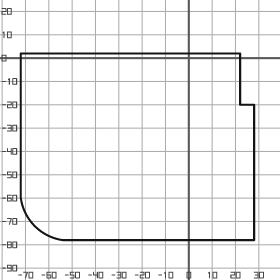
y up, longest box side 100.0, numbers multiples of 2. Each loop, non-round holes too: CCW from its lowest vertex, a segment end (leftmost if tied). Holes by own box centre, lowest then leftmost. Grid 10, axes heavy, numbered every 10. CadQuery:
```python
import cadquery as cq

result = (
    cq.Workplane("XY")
    .moveTo(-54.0, -78.0)
    .lineTo(28.0, -78.0)
    .lineTo(28.0, -20.0)
    .lineTo(22.0, -20.0)
    .lineTo(22.0, 2.0)
    .lineTo(-72.0, 2.0)
    .lineTo(-72.0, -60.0)
    .threePointArc((-66.0, -72.0), (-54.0, -78.0))
    .close()
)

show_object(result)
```